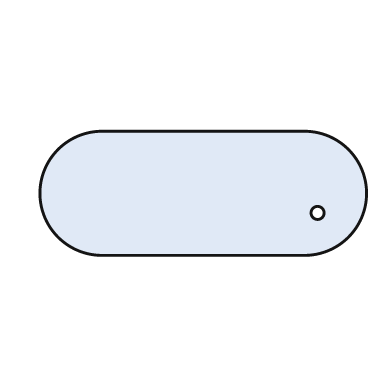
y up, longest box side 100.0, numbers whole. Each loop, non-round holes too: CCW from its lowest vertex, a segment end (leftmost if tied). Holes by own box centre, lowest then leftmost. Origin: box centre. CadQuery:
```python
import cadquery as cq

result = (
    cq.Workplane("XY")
    .moveTo(-31.0, -19.0)
    .lineTo(31.0, -19.0)
    .threePointArc((50.0, 0.0), (31.0, 19.0))
    .lineTo(-31.0, 19.0)
    .threePointArc((-50.0, 0.0), (-31.0, -19.0))
    .close()
    .moveTo(35.0, -6.0)
    .circle(2.0)
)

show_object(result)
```